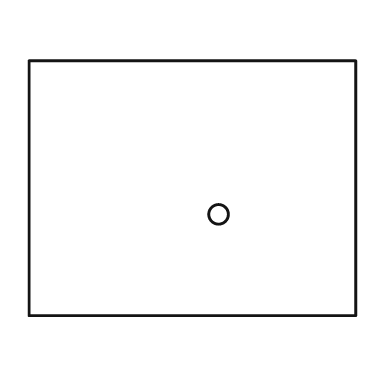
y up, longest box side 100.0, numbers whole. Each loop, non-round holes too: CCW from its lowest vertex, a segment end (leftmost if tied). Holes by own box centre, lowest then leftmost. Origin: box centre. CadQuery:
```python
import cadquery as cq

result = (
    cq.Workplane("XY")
    .moveTo(-50.0, -39.0)
    .lineTo(50.0, -39.0)
    .lineTo(50.0, 39.0)
    .lineTo(-50.0, 39.0)
    .close()
    .moveTo(8.0, -8.0)
    .circle(3.0)
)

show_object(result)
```